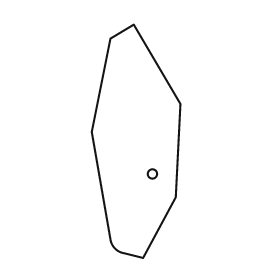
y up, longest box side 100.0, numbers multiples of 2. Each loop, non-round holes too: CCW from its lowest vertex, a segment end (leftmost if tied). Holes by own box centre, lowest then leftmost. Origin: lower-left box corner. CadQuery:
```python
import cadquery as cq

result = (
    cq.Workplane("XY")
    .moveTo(22.0, 0.0)
    .lineTo(36.0, 26.0)
    .lineTo(38.0, 66.0)
    .lineTo(18.0, 100.0)
    .lineTo(8.0, 94.0)
    .lineTo(0.0, 54.0)
    .lineTo(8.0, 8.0)
    .threePointArc((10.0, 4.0), (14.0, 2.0))
    .close()
    .moveTo(26.0, 36.0)
    .circle(2.0)
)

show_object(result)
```